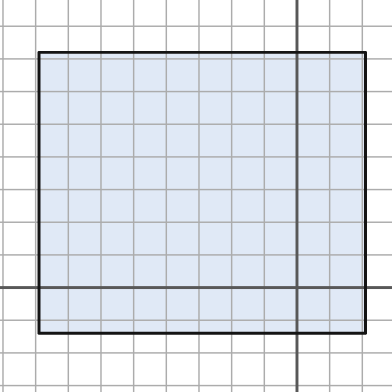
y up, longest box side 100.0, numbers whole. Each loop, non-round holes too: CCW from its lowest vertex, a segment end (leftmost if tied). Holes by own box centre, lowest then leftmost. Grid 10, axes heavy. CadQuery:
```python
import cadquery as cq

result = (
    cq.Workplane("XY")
    .moveTo(-79.0, -14.0)
    .lineTo(21.0, -14.0)
    .lineTo(21.0, 72.0)
    .lineTo(-79.0, 72.0)
    .close()
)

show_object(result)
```